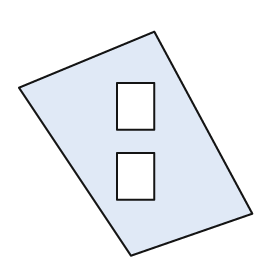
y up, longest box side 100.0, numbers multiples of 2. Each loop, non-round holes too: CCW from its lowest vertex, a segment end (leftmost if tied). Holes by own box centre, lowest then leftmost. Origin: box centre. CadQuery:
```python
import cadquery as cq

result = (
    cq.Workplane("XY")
    .moveTo(-2.0, -48.0)
    .lineTo(50.0, -30.0)
    .lineTo(8.0, 48.0)
    .lineTo(-50.0, 24.0)
    .close()
    .moveTo(-8.0, -24.0)
    .lineTo(8.0, -24.0)
    .lineTo(8.0, -4.0)
    .lineTo(-8.0, -4.0)
    .close()
    .moveTo(-8.0, 6.0)
    .lineTo(8.0, 6.0)
    .lineTo(8.0, 26.0)
    .lineTo(-8.0, 26.0)
    .close()
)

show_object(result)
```